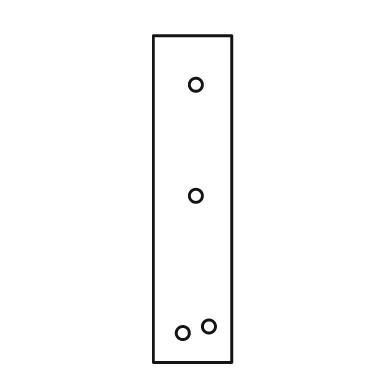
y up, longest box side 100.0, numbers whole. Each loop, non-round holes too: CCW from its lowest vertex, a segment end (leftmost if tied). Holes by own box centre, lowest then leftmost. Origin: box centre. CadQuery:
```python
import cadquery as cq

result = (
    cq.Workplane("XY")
    .moveTo(-12.0, -50.0)
    .lineTo(12.0, -50.0)
    .lineTo(12.0, 50.0)
    .lineTo(-12.0, 50.0)
    .close()
    .moveTo(-3.0, -41.0)
    .circle(2.0)
    .moveTo(5.0, -39.0)
    .circle(2.0)
    .moveTo(1.0, 1.0)
    .circle(2.0)
    .moveTo(1.0, 35.0)
    .circle(2.0)
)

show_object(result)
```